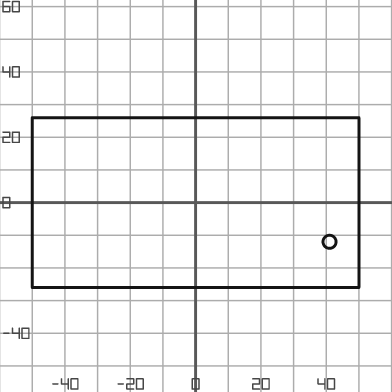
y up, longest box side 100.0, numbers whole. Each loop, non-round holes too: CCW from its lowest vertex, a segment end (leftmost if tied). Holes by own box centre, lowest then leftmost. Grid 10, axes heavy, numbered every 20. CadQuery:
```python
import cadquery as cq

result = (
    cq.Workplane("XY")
    .moveTo(-50.0, -26.0)
    .lineTo(50.0, -26.0)
    .lineTo(50.0, 26.0)
    .lineTo(-50.0, 26.0)
    .close()
    .moveTo(41.0, -12.0)
    .circle(2.0)
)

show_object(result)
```